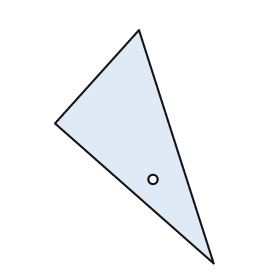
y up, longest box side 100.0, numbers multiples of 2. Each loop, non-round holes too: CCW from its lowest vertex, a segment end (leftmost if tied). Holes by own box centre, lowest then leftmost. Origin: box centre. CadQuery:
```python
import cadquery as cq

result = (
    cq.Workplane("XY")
    .moveTo(34.0, -50.0)
    .lineTo(2.0, 50.0)
    .lineTo(-34.0, 10.0)
    .close()
    .moveTo(8.0, -14.0)
    .circle(2.0)
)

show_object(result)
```